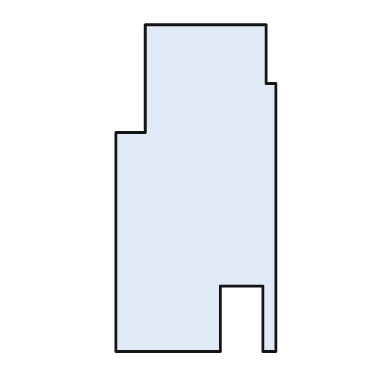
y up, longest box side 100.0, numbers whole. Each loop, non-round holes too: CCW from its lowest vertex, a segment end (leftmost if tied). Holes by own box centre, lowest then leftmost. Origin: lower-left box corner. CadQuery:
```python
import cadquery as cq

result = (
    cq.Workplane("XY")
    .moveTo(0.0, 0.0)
    .lineTo(32.0, 0.0)
    .lineTo(32.0, 20.0)
    .lineTo(45.0, 20.0)
    .lineTo(45.0, 0.0)
    .lineTo(49.0, 0.0)
    .lineTo(49.0, 82.0)
    .lineTo(46.0, 82.0)
    .lineTo(46.0, 100.0)
    .lineTo(9.0, 100.0)
    .lineTo(9.0, 67.0)
    .lineTo(0.0, 67.0)
    .close()
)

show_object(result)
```